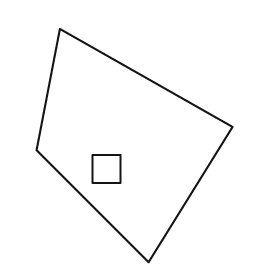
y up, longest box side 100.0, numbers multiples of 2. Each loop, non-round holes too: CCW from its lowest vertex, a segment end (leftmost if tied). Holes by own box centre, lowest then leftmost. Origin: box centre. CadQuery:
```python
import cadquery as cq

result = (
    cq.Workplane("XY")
    .moveTo(6.0, -50.0)
    .lineTo(42.0, 8.0)
    .lineTo(-32.0, 50.0)
    .lineTo(-42.0, -2.0)
    .close()
    .moveTo(-18.0, -16.0)
    .lineTo(-6.0, -16.0)
    .lineTo(-6.0, -4.0)
    .lineTo(-18.0, -4.0)
    .close()
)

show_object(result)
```